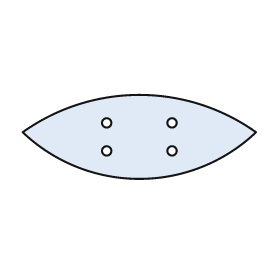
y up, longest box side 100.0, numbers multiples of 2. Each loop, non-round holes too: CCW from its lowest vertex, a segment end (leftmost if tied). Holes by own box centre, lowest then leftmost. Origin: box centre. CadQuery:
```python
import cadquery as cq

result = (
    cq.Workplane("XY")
    .moveTo(-50.0, 2.0)
    .threePointArc((0.0, -18.0), (50.0, 2.0))
    .threePointArc((0.0, 18.0), (-50.0, 2.0))
    .close()
    .moveTo(-14.0, -6.0)
    .circle(2.0)
    .moveTo(14.0, -6.0)
    .circle(2.0)
    .moveTo(-14.0, 6.0)
    .circle(2.0)
    .moveTo(14.0, 6.0)
    .circle(2.0)
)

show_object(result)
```